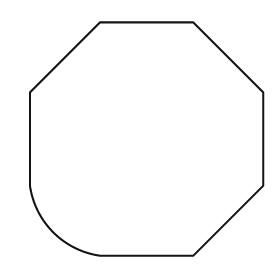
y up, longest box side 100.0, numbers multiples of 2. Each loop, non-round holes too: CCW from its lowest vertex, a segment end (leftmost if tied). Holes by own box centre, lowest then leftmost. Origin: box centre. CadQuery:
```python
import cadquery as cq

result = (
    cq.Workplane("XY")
    .moveTo(-20.0, -50.0)
    .lineTo(20.0, -50.0)
    .lineTo(50.0, -20.0)
    .lineTo(50.0, 20.0)
    .lineTo(20.0, 50.0)
    .lineTo(-20.0, 50.0)
    .lineTo(-50.0, 20.0)
    .lineTo(-50.0, -20.0)
    .threePointArc((-40.0, -40.0), (-20.0, -50.0))
    .close()
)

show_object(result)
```